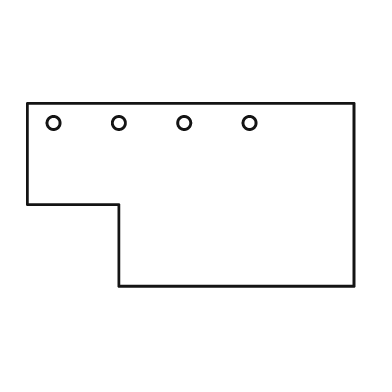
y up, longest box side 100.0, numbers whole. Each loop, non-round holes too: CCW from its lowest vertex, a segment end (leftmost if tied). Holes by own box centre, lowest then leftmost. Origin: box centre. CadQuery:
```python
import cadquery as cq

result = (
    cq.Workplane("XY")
    .moveTo(-22.0, -28.0)
    .lineTo(50.0, -28.0)
    .lineTo(50.0, 28.0)
    .lineTo(-50.0, 28.0)
    .lineTo(-50.0, -3.0)
    .lineTo(-22.0, -3.0)
    .close()
    .moveTo(-42.0, 22.0)
    .circle(2.0)
    .moveTo(-22.0, 22.0)
    .circle(2.0)
    .moveTo(-2.0, 22.0)
    .circle(2.0)
    .moveTo(18.0, 22.0)
    .circle(2.0)
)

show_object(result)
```